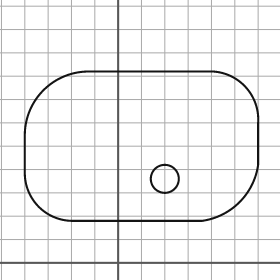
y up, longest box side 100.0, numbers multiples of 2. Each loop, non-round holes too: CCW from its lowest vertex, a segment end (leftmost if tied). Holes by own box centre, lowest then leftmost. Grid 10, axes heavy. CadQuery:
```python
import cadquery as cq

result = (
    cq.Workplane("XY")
    .moveTo(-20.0, 18.0)
    .lineTo(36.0, 18.0)
    .threePointArc((52.0, 26.0), (60.0, 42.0))
    .lineTo(60.0, 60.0)
    .threePointArc((54.0, 76.0), (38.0, 82.0))
    .lineTo(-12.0, 82.0)
    .threePointArc((-32.0, 74.0), (-40.0, 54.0))
    .lineTo(-40.0, 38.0)
    .threePointArc((-34.0, 24.0), (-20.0, 18.0))
    .close()
    .moveTo(20.0, 36.0)
    .circle(6.0)
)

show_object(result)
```